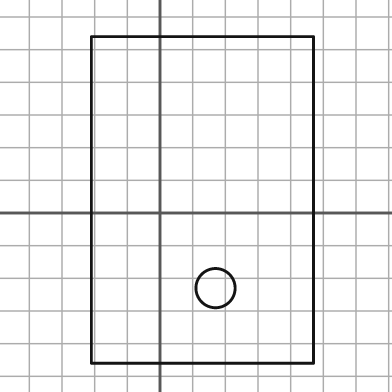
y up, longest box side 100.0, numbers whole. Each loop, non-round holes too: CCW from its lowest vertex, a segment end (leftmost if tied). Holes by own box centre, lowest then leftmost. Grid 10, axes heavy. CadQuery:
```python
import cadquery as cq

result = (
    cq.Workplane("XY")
    .moveTo(-21.0, -46.0)
    .lineTo(47.0, -46.0)
    .lineTo(47.0, 54.0)
    .lineTo(-21.0, 54.0)
    .close()
    .moveTo(17.0, -23.0)
    .circle(6.0)
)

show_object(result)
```